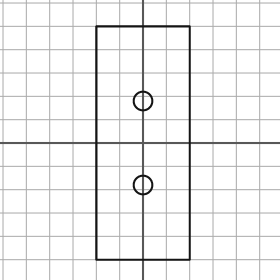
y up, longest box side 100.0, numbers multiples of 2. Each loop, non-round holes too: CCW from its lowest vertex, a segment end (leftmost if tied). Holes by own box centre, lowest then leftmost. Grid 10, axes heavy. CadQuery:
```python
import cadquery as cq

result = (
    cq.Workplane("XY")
    .moveTo(-20.0, -50.0)
    .lineTo(20.0, -50.0)
    .lineTo(20.0, 50.0)
    .lineTo(-20.0, 50.0)
    .close()
    .moveTo(0.0, -18.0)
    .circle(4.0)
    .moveTo(0.0, 18.0)
    .circle(4.0)
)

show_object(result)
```